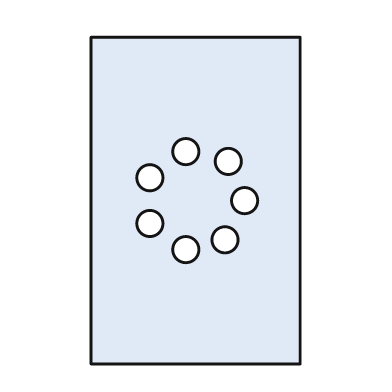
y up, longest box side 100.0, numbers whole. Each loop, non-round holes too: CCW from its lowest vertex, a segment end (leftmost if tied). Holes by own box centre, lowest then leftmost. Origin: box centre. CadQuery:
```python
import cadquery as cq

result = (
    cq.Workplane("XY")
    .moveTo(-32.0, -50.0)
    .lineTo(32.0, -50.0)
    .lineTo(32.0, 50.0)
    .lineTo(-32.0, 50.0)
    .close()
    .moveTo(-3.0, -15.0)
    .circle(4.0)
    .moveTo(9.0, -12.0)
    .circle(4.0)
    .moveTo(-14.0, -7.0)
    .circle(4.0)
    .moveTo(15.0, 0.0)
    .circle(4.0)
    .moveTo(-14.0, 7.0)
    .circle(4.0)
    .moveTo(10.0, 12.0)
    .circle(4.0)
    .moveTo(-3.0, 15.0)
    .circle(4.0)
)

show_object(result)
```